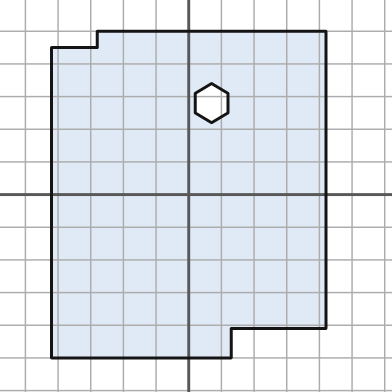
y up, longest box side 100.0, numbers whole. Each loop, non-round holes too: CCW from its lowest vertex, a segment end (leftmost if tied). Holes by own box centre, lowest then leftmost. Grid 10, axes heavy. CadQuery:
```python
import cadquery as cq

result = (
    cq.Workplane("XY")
    .moveTo(-42.0, -50.0)
    .lineTo(13.0, -50.0)
    .lineTo(13.0, -41.0)
    .lineTo(42.0, -41.0)
    .lineTo(42.0, 50.0)
    .lineTo(-28.0, 50.0)
    .lineTo(-28.0, 45.0)
    .lineTo(-42.0, 45.0)
    .close()
    .moveTo(7.0, 22.0)
    .lineTo(12.0, 25.0)
    .lineTo(12.0, 31.0)
    .lineTo(7.0, 34.0)
    .lineTo(2.0, 31.0)
    .lineTo(2.0, 25.0)
    .close()
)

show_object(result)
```